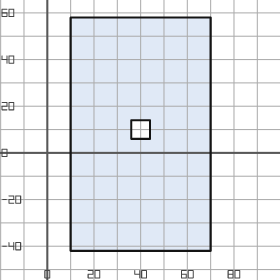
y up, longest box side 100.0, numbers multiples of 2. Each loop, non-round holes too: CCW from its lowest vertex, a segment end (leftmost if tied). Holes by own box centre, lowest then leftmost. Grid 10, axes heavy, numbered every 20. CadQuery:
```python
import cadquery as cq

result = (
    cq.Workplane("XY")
    .moveTo(10.0, -42.0)
    .lineTo(70.0, -42.0)
    .lineTo(70.0, 58.0)
    .lineTo(10.0, 58.0)
    .close()
    .moveTo(36.0, 6.0)
    .lineTo(44.0, 6.0)
    .lineTo(44.0, 14.0)
    .lineTo(36.0, 14.0)
    .close()
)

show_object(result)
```